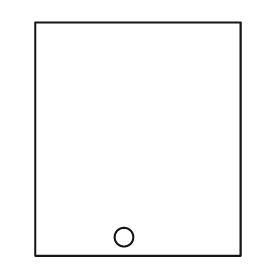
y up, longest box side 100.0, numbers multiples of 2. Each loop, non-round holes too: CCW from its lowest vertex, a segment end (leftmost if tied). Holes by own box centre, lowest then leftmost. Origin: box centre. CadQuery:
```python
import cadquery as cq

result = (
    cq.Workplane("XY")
    .moveTo(-44.0, -50.0)
    .lineTo(44.0, -50.0)
    .lineTo(44.0, 50.0)
    .lineTo(-44.0, 50.0)
    .close()
    .moveTo(-6.0, -42.0)
    .circle(4.0)
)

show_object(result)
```